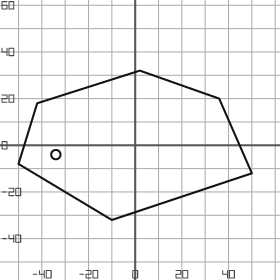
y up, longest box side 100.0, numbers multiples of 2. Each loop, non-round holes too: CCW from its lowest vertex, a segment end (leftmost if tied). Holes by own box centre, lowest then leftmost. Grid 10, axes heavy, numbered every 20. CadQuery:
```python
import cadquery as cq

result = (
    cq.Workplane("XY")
    .moveTo(-10.0, -32.0)
    .lineTo(50.0, -12.0)
    .lineTo(36.0, 20.0)
    .lineTo(2.0, 32.0)
    .lineTo(-42.0, 18.0)
    .lineTo(-50.0, -8.0)
    .close()
    .moveTo(-34.0, -4.0)
    .circle(2.0)
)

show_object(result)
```